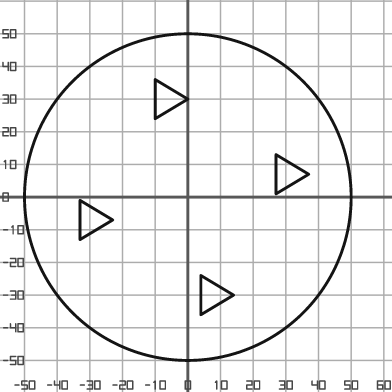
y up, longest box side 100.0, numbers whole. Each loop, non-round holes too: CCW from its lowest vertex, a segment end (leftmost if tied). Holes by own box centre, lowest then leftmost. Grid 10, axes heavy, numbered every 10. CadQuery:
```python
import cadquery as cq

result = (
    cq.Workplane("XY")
    .moveTo(0.0, 0.0)
    .circle(50.0)
    .moveTo(4.0, -36.0)
    .lineTo(14.0, -30.0)
    .lineTo(4.0, -24.0)
    .close()
    .moveTo(-33.0, -13.0)
    .lineTo(-23.0, -7.0)
    .lineTo(-33.0, -1.0)
    .close()
    .moveTo(27.0, 1.0)
    .lineTo(37.0, 7.0)
    .lineTo(27.0, 13.0)
    .close()
    .moveTo(-10.0, 24.0)
    .lineTo(0.0, 30.0)
    .lineTo(-10.0, 36.0)
    .close()
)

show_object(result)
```